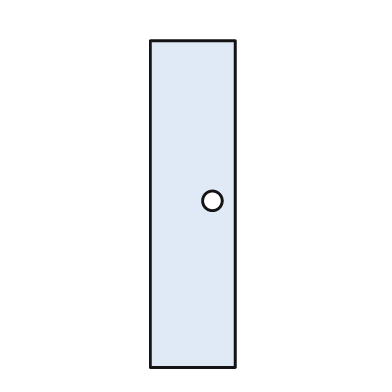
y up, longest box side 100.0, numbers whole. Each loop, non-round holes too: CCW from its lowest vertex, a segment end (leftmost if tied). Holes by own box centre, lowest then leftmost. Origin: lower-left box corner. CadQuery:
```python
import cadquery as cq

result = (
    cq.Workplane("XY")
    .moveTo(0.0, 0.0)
    .lineTo(26.0, 0.0)
    .lineTo(26.0, 100.0)
    .lineTo(0.0, 100.0)
    .close()
    .moveTo(19.0, 51.0)
    .circle(3.0)
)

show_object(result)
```